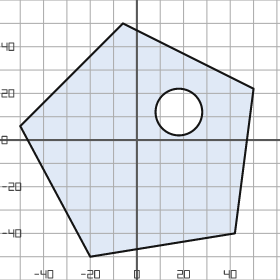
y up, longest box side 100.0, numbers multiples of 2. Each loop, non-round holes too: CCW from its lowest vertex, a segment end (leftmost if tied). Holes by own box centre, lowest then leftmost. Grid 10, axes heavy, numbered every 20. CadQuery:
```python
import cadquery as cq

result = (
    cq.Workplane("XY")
    .moveTo(-20.0, -50.0)
    .lineTo(42.0, -40.0)
    .lineTo(50.0, 22.0)
    .lineTo(-6.0, 50.0)
    .lineTo(-50.0, 6.0)
    .close()
    .moveTo(18.0, 12.0)
    .circle(10.0)
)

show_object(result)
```